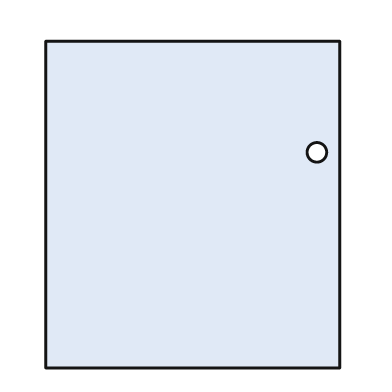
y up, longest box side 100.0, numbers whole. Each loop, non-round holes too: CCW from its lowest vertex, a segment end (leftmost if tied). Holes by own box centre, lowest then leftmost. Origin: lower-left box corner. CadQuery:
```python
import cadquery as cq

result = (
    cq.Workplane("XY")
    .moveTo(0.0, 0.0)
    .lineTo(90.0, 0.0)
    .lineTo(90.0, 100.0)
    .lineTo(0.0, 100.0)
    .close()
    .moveTo(83.0, 66.0)
    .circle(3.0)
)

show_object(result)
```